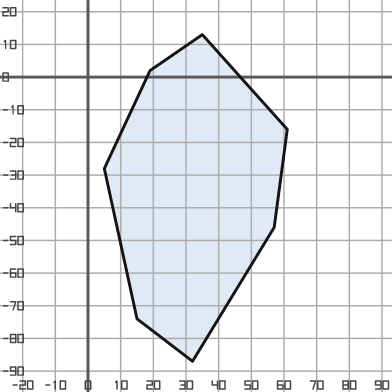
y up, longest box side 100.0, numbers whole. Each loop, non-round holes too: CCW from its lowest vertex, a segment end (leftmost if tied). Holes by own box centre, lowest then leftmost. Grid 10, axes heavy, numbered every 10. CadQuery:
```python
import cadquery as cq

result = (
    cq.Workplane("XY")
    .moveTo(32.0, -87.0)
    .lineTo(57.0, -46.0)
    .lineTo(61.0, -16.0)
    .lineTo(35.0, 13.0)
    .lineTo(19.0, 2.0)
    .lineTo(5.0, -28.0)
    .lineTo(15.0, -74.0)
    .close()
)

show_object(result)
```